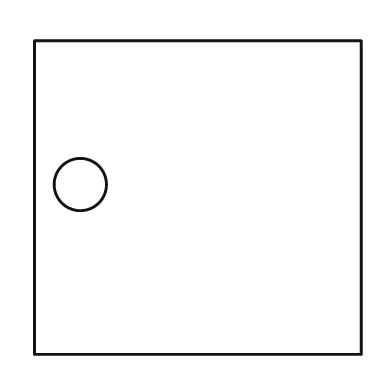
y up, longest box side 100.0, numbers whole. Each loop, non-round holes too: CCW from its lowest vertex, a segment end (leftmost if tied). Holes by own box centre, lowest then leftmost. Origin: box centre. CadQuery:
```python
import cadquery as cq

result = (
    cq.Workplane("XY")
    .moveTo(-50.0, -48.0)
    .lineTo(50.0, -48.0)
    .lineTo(50.0, 48.0)
    .lineTo(-50.0, 48.0)
    .close()
    .moveTo(-36.0, 4.0)
    .circle(8.0)
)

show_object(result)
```